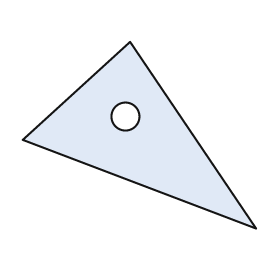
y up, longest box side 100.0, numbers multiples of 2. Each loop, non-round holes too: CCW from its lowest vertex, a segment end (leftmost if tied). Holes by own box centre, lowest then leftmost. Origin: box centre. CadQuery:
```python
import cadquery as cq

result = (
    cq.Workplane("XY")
    .moveTo(50.0, -40.0)
    .lineTo(-4.0, 40.0)
    .lineTo(-50.0, -2.0)
    .close()
    .moveTo(-6.0, 8.0)
    .circle(6.0)
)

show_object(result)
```